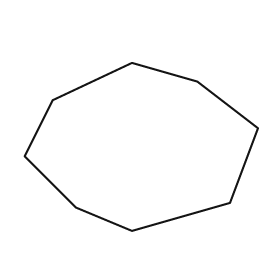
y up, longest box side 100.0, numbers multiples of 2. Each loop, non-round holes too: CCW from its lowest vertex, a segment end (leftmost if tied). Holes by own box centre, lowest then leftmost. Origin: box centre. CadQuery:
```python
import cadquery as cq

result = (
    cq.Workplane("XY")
    .moveTo(-4.0, -36.0)
    .lineTo(38.0, -24.0)
    .lineTo(50.0, 8.0)
    .lineTo(24.0, 28.0)
    .lineTo(-4.0, 36.0)
    .lineTo(-38.0, 20.0)
    .lineTo(-50.0, -4.0)
    .lineTo(-28.0, -26.0)
    .close()
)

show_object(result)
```